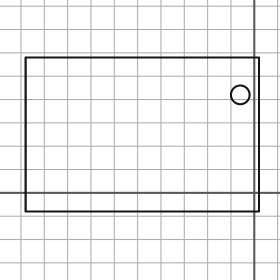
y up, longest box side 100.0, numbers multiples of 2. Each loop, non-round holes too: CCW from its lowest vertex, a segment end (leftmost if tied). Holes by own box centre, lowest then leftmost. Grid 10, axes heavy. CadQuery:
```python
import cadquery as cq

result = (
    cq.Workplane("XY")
    .moveTo(-98.0, -8.0)
    .lineTo(2.0, -8.0)
    .lineTo(2.0, 58.0)
    .lineTo(-98.0, 58.0)
    .close()
    .moveTo(-6.0, 42.0)
    .circle(4.0)
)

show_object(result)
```